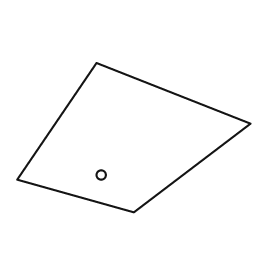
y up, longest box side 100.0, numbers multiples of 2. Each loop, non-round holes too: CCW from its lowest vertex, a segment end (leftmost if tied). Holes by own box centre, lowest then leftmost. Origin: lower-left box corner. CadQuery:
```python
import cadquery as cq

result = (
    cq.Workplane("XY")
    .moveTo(50.0, 0.0)
    .lineTo(100.0, 38.0)
    .lineTo(34.0, 64.0)
    .lineTo(0.0, 14.0)
    .close()
    .moveTo(36.0, 16.0)
    .circle(2.0)
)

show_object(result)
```